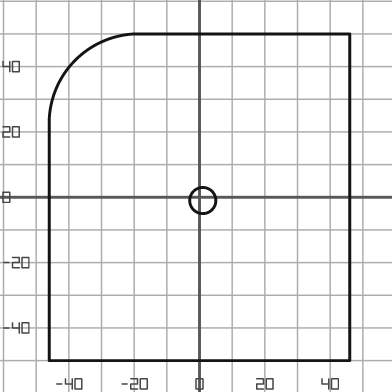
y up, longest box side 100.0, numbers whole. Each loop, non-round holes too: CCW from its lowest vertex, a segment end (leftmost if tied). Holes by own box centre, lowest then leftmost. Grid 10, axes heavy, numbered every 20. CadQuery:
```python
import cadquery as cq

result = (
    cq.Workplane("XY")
    .moveTo(-46.0, -50.0)
    .lineTo(46.0, -50.0)
    .lineTo(46.0, 50.0)
    .lineTo(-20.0, 50.0)
    .threePointArc((-38.0, 42.0), (-46.0, 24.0))
    .close()
    .moveTo(1.0, -1.0)
    .circle(4.0)
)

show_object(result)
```